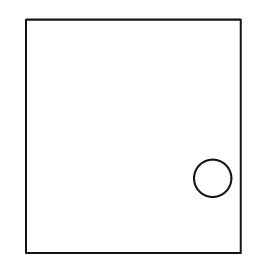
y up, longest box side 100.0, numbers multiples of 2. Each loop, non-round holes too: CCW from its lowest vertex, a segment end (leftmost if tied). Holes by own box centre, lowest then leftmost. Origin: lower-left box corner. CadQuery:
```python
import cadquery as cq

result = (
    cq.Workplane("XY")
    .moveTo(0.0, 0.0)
    .lineTo(92.0, 0.0)
    .lineTo(92.0, 100.0)
    .lineTo(0.0, 100.0)
    .close()
    .moveTo(80.0, 32.0)
    .circle(8.0)
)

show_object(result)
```